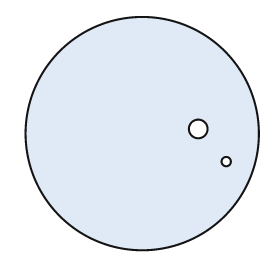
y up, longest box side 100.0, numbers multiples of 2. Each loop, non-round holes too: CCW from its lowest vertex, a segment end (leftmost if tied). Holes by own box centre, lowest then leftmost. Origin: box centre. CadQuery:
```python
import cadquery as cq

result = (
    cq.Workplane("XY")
    .moveTo(0.0, 0.0)
    .circle(50.0)
    .moveTo(36.0, -12.0)
    .circle(2.0)
    .moveTo(24.0, 2.0)
    .circle(4.0)
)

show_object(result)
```